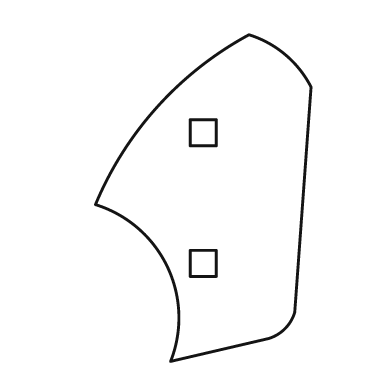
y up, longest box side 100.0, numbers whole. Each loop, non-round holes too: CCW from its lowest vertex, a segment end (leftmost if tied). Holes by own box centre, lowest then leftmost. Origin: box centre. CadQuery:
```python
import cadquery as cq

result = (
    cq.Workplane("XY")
    .moveTo(-10.0, -50.0)
    .lineTo(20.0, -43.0)
    .threePointArc((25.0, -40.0), (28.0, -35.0))
    .lineTo(33.0, 34.0)
    .threePointArc((25.0, 44.0), (14.0, 50.0))
    .threePointArc((-14.0, 28.0), (-33.0, -2.0))
    .threePointArc((-11.0, -21.0), (-10.0, -50.0))
    .close()
    .moveTo(-4.0, -24.0)
    .lineTo(4.0, -24.0)
    .lineTo(4.0, -16.0)
    .lineTo(-4.0, -16.0)
    .close()
    .moveTo(-4.0, 16.0)
    .lineTo(4.0, 16.0)
    .lineTo(4.0, 24.0)
    .lineTo(-4.0, 24.0)
    .close()
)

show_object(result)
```